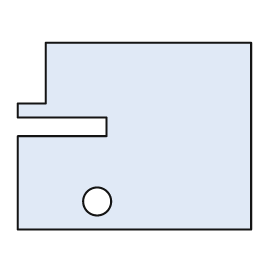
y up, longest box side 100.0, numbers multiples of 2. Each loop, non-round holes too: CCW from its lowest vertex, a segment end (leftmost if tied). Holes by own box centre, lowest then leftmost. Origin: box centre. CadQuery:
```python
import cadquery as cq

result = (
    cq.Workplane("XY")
    .moveTo(-50.0, -40.0)
    .lineTo(50.0, -40.0)
    .lineTo(50.0, 40.0)
    .lineTo(-38.0, 40.0)
    .lineTo(-38.0, 14.0)
    .lineTo(-50.0, 14.0)
    .lineTo(-50.0, 8.0)
    .lineTo(-12.0, 8.0)
    .lineTo(-12.0, 0.0)
    .lineTo(-50.0, 0.0)
    .close()
    .moveTo(-16.0, -28.0)
    .circle(6.0)
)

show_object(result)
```